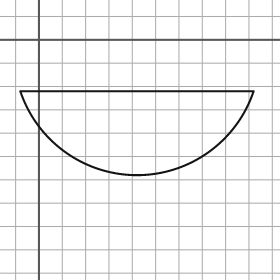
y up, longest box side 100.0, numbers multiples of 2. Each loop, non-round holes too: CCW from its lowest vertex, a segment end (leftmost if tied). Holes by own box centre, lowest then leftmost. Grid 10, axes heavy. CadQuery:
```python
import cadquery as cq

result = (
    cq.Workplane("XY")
    .moveTo(-8.0, -22.0)
    .threePointArc((42.0, -58.0), (92.0, -22.0))
    .close()
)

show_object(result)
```